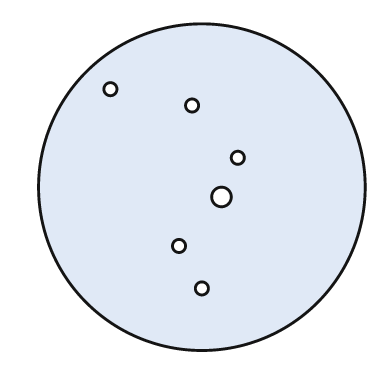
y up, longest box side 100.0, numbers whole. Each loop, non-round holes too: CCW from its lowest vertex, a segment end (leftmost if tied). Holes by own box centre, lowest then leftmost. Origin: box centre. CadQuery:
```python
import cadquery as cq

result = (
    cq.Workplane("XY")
    .moveTo(0.0, 0.0)
    .circle(50.0)
    .moveTo(0.0, -31.0)
    .circle(2.0)
    .moveTo(-7.0, -18.0)
    .circle(2.0)
    .moveTo(6.0, -3.0)
    .circle(3.0)
    .moveTo(11.0, 9.0)
    .circle(2.0)
    .moveTo(-3.0, 25.0)
    .circle(2.0)
    .moveTo(-28.0, 30.0)
    .circle(2.0)
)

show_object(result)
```